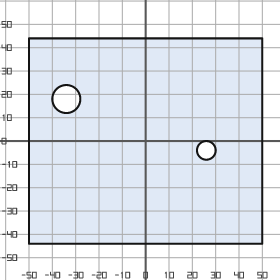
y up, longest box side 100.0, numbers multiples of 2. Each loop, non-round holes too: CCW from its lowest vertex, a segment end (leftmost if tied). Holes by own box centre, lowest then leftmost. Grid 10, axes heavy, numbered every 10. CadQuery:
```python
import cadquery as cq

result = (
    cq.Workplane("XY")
    .moveTo(-50.0, -44.0)
    .lineTo(50.0, -44.0)
    .lineTo(50.0, 44.0)
    .lineTo(-50.0, 44.0)
    .close()
    .moveTo(26.0, -4.0)
    .circle(4.0)
    .moveTo(-34.0, 18.0)
    .circle(6.0)
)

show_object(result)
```